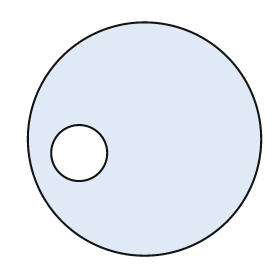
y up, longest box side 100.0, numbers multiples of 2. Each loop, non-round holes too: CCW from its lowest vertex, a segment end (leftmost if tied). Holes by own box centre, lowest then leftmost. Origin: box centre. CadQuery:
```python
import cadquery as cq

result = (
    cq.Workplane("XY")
    .moveTo(0.0, 0.0)
    .circle(50.0)
    .moveTo(-28.0, -6.0)
    .circle(12.0)
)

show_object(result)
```